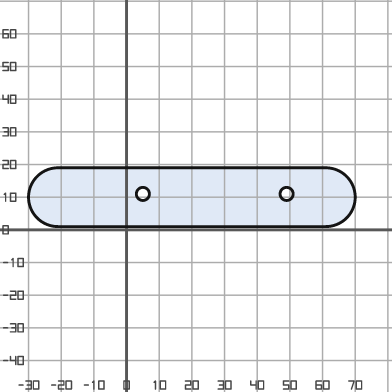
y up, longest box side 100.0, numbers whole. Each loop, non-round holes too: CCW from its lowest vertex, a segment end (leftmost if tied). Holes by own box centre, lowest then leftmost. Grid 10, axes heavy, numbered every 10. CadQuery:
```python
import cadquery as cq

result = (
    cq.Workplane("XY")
    .moveTo(-21.0, 1.0)
    .lineTo(61.0, 1.0)
    .threePointArc((70.0, 10.0), (61.0, 19.0))
    .lineTo(-21.0, 19.0)
    .threePointArc((-30.0, 10.0), (-21.0, 1.0))
    .close()
    .moveTo(5.0, 11.0)
    .circle(2.0)
    .moveTo(49.0, 11.0)
    .circle(2.0)
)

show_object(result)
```